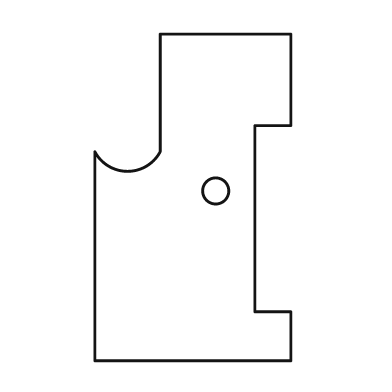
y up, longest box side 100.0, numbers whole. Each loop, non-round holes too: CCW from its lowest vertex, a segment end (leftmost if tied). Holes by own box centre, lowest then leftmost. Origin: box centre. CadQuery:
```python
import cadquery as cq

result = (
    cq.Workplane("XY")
    .moveTo(-30.0, -50.0)
    .lineTo(30.0, -50.0)
    .lineTo(30.0, -35.0)
    .lineTo(19.0, -35.0)
    .lineTo(19.0, 22.0)
    .lineTo(30.0, 22.0)
    .lineTo(30.0, 50.0)
    .lineTo(-10.0, 50.0)
    .lineTo(-10.0, 14.0)
    .threePointArc((-20.0, 8.0), (-30.0, 14.0))
    .close()
    .moveTo(7.0, 2.0)
    .circle(4.0)
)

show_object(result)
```